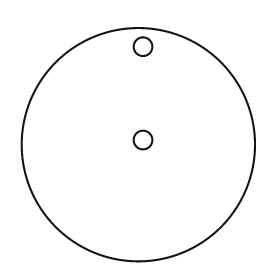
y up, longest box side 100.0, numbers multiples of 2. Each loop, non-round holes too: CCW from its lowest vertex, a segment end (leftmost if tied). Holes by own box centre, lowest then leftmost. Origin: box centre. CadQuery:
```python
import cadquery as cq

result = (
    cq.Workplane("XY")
    .moveTo(0.0, 0.0)
    .circle(50.0)
    .moveTo(2.0, 2.0)
    .circle(4.0)
    .moveTo(2.0, 42.0)
    .circle(4.0)
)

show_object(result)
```